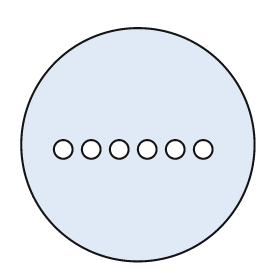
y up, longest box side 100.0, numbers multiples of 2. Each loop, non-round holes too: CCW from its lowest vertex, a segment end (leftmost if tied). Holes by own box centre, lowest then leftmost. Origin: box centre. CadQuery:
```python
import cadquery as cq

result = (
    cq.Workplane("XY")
    .moveTo(0.0, 0.0)
    .circle(50.0)
    .moveTo(-32.0, -2.0)
    .circle(4.0)
    .moveTo(-20.0, -2.0)
    .circle(4.0)
    .moveTo(-8.0, -2.0)
    .circle(4.0)
    .moveTo(4.0, -2.0)
    .circle(4.0)
    .moveTo(16.0, -2.0)
    .circle(4.0)
    .moveTo(28.0, -2.0)
    .circle(4.0)
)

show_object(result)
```